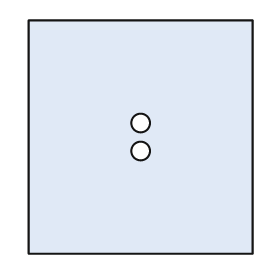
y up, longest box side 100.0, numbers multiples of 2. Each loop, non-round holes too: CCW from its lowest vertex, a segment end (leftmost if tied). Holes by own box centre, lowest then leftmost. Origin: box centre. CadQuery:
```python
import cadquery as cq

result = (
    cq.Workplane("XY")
    .moveTo(-48.0, -50.0)
    .lineTo(48.0, -50.0)
    .lineTo(48.0, 50.0)
    .lineTo(-48.0, 50.0)
    .close()
    .moveTo(0.0, -6.0)
    .circle(4.0)
    .moveTo(0.0, 6.0)
    .circle(4.0)
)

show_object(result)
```